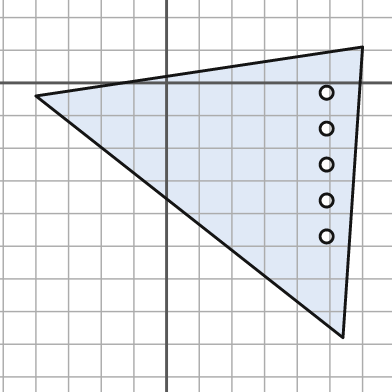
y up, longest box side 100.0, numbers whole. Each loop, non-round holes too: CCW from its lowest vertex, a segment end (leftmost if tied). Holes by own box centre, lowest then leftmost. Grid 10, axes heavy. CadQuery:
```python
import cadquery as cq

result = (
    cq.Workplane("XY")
    .moveTo(54.0, -78.0)
    .lineTo(60.0, 11.0)
    .lineTo(-40.0, -4.0)
    .close()
    .moveTo(49.0, -47.0)
    .circle(2.0)
    .moveTo(49.0, -36.0)
    .circle(2.0)
    .moveTo(49.0, -25.0)
    .circle(2.0)
    .moveTo(49.0, -14.0)
    .circle(2.0)
    .moveTo(49.0, -3.0)
    .circle(2.0)
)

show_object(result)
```